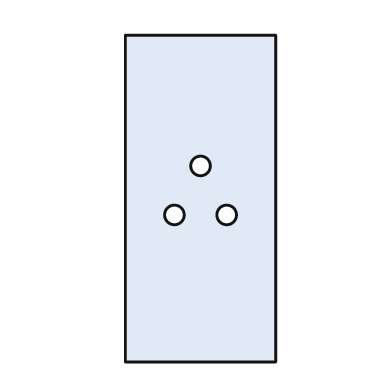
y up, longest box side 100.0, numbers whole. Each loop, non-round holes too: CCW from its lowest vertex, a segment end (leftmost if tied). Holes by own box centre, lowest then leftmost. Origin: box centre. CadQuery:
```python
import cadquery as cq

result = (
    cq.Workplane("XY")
    .moveTo(-23.0, -50.0)
    .lineTo(23.0, -50.0)
    .lineTo(23.0, 50.0)
    .lineTo(-23.0, 50.0)
    .close()
    .moveTo(-8.0, -5.0)
    .circle(3.0)
    .moveTo(8.0, -5.0)
    .circle(3.0)
    .moveTo(0.0, 10.0)
    .circle(3.0)
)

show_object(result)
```